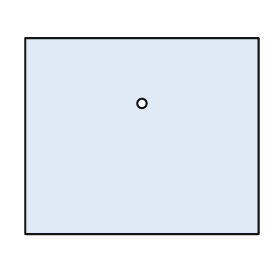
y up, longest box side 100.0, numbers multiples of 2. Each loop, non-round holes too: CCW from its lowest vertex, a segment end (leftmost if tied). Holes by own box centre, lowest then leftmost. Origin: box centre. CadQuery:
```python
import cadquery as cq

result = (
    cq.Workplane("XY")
    .moveTo(-50.0, -42.0)
    .lineTo(50.0, -42.0)
    .lineTo(50.0, 42.0)
    .lineTo(-50.0, 42.0)
    .close()
    .moveTo(0.0, 14.0)
    .circle(2.0)
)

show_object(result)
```